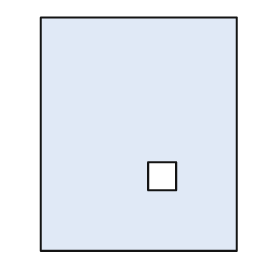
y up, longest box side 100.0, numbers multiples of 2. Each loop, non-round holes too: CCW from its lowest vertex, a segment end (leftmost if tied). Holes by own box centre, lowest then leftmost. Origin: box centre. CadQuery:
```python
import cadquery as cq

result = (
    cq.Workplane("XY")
    .moveTo(-42.0, -50.0)
    .lineTo(42.0, -50.0)
    .lineTo(42.0, 50.0)
    .lineTo(-42.0, 50.0)
    .close()
    .moveTo(4.0, -24.0)
    .lineTo(16.0, -24.0)
    .lineTo(16.0, -12.0)
    .lineTo(4.0, -12.0)
    .close()
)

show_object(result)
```